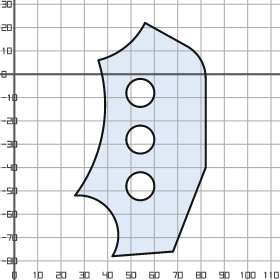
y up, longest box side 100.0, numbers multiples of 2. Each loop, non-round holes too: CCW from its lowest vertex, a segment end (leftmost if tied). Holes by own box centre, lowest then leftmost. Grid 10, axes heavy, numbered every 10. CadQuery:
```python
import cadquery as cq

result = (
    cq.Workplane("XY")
    .moveTo(42.0, -78.0)
    .lineTo(68.0, -76.0)
    .lineTo(82.0, -40.0)
    .lineTo(82.0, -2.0)
    .threePointArc((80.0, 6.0), (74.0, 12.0))
    .lineTo(56.0, 22.0)
    .threePointArc((48.0, 12.0), (36.0, 6.0))
    .threePointArc((38.0, -24.0), (26.0, -52.0))
    .threePointArc((42.0, -60.0), (42.0, -78.0))
    .close()
    .moveTo(54.0, -48.0)
    .circle(6.0)
    .moveTo(54.0, -28.0)
    .circle(6.0)
    .moveTo(54.0, -8.0)
    .circle(6.0)
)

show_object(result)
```